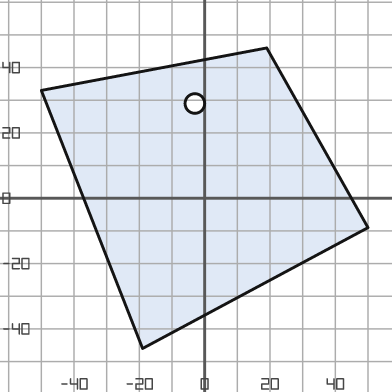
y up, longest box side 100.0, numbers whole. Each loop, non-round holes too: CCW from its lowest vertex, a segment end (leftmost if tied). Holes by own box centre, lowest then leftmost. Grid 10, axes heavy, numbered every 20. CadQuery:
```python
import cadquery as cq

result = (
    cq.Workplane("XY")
    .moveTo(-19.0, -46.0)
    .lineTo(50.0, -9.0)
    .lineTo(19.0, 46.0)
    .lineTo(-50.0, 33.0)
    .close()
    .moveTo(-3.0, 29.0)
    .circle(3.0)
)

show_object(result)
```